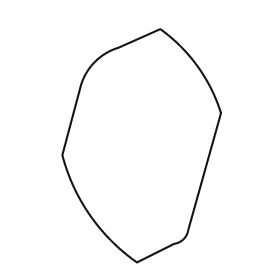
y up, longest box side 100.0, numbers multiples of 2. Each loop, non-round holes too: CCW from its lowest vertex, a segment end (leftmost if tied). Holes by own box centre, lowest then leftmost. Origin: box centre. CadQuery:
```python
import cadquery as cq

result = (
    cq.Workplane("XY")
    .moveTo(-2.0, -50.0)
    .lineTo(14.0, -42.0)
    .threePointArc((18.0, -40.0), (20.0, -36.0))
    .lineTo(34.0, 14.0)
    .threePointArc((24.0, 34.0), (8.0, 50.0))
    .lineTo(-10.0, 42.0)
    .threePointArc((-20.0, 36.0), (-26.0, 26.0))
    .lineTo(-34.0, -4.0)
    .threePointArc((-22.0, -30.0), (-2.0, -50.0))
    .close()
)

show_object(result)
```